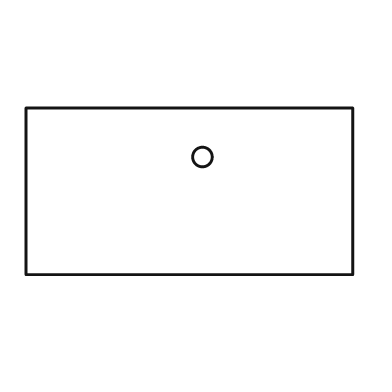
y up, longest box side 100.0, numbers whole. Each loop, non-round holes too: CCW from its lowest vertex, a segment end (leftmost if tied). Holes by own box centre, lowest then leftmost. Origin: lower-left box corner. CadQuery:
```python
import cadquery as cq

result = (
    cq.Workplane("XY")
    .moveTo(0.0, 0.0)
    .lineTo(100.0, 0.0)
    .lineTo(100.0, 51.0)
    .lineTo(0.0, 51.0)
    .close()
    .moveTo(54.0, 36.0)
    .circle(3.0)
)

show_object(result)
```